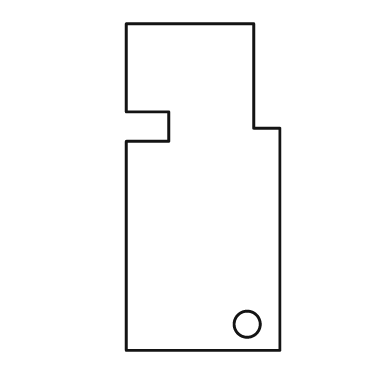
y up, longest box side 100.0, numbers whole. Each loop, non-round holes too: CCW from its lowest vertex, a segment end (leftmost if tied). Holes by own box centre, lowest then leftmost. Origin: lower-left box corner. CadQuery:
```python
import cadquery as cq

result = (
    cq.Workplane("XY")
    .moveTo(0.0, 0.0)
    .lineTo(47.0, 0.0)
    .lineTo(47.0, 68.0)
    .lineTo(39.0, 68.0)
    .lineTo(39.0, 100.0)
    .lineTo(0.0, 100.0)
    .lineTo(0.0, 73.0)
    .lineTo(13.0, 73.0)
    .lineTo(13.0, 64.0)
    .lineTo(0.0, 64.0)
    .close()
    .moveTo(37.0, 8.0)
    .circle(4.0)
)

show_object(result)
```